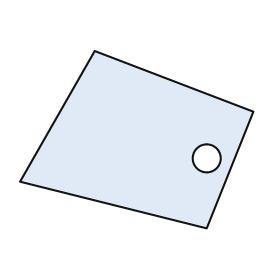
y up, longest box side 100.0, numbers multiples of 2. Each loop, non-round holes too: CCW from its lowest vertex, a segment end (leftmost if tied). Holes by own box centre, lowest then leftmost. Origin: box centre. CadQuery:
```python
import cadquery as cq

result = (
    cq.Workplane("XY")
    .moveTo(30.0, -38.0)
    .lineTo(50.0, 12.0)
    .lineTo(-18.0, 38.0)
    .lineTo(-50.0, -18.0)
    .close()
    .moveTo(30.0, -8.0)
    .circle(6.0)
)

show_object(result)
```